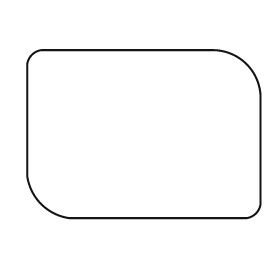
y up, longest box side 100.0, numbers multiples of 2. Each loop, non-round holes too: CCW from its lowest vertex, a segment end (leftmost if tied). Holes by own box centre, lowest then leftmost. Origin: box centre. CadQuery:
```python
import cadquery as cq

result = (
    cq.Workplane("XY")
    .moveTo(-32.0, -36.0)
    .lineTo(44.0, -36.0)
    .threePointArc((48.0, -34.0), (50.0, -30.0))
    .lineTo(50.0, 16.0)
    .threePointArc((44.0, 30.0), (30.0, 36.0))
    .lineTo(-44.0, 36.0)
    .threePointArc((-48.0, 34.0), (-50.0, 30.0))
    .lineTo(-50.0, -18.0)
    .threePointArc((-44.0, -30.0), (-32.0, -36.0))
    .close()
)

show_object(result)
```